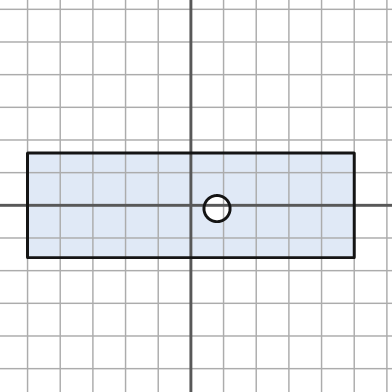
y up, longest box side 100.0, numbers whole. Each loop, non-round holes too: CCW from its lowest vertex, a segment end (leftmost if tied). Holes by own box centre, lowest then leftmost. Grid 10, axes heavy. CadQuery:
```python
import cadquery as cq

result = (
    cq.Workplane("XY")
    .moveTo(-50.0, -16.0)
    .lineTo(50.0, -16.0)
    .lineTo(50.0, 16.0)
    .lineTo(-50.0, 16.0)
    .close()
    .moveTo(8.0, -1.0)
    .circle(4.0)
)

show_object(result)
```